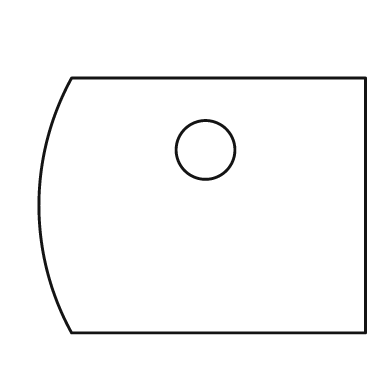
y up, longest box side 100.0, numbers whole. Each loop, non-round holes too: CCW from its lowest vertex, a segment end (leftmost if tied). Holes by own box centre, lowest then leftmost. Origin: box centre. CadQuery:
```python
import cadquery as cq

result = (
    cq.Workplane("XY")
    .moveTo(-40.0, -39.0)
    .lineTo(50.0, -39.0)
    .lineTo(50.0, 39.0)
    .lineTo(-40.0, 39.0)
    .threePointArc((-50.0, 0.0), (-40.0, -39.0))
    .close()
    .moveTo(1.0, 17.0)
    .circle(9.0)
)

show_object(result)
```